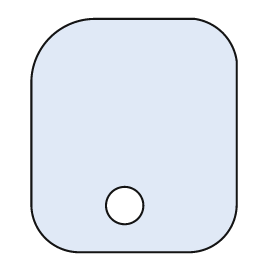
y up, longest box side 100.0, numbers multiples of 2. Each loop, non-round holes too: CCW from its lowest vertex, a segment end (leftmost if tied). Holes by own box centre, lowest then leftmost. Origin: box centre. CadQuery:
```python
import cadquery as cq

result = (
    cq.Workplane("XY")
    .moveTo(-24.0, -50.0)
    .lineTo(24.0, -50.0)
    .threePointArc((38.0, -44.0), (44.0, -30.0))
    .lineTo(44.0, 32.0)
    .threePointArc((38.0, 44.0), (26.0, 50.0))
    .lineTo(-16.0, 50.0)
    .threePointArc((-36.0, 42.0), (-44.0, 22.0))
    .lineTo(-44.0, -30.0)
    .threePointArc((-38.0, -44.0), (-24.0, -50.0))
    .close()
    .moveTo(-4.0, -30.0)
    .circle(8.0)
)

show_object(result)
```